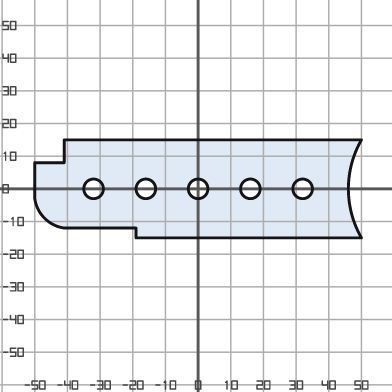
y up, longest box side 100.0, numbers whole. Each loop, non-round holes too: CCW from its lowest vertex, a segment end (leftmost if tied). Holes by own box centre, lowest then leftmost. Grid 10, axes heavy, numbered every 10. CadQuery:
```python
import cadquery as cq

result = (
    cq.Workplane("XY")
    .moveTo(-19.0, -15.0)
    .lineTo(50.0, -15.0)
    .threePointArc((46.0, 0.0), (50.0, 15.0))
    .lineTo(-41.0, 15.0)
    .lineTo(-41.0, 8.0)
    .lineTo(-50.0, 8.0)
    .lineTo(-50.0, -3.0)
    .threePointArc((-47.0, -9.0), (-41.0, -12.0))
    .lineTo(-19.0, -12.0)
    .close()
    .moveTo(-32.0, 0.0)
    .circle(3.0)
    .moveTo(-16.0, 0.0)
    .circle(3.0)
    .moveTo(0.0, 0.0)
    .circle(3.0)
    .moveTo(16.0, 0.0)
    .circle(3.0)
    .moveTo(32.0, 0.0)
    .circle(3.0)
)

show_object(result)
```